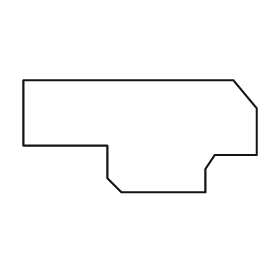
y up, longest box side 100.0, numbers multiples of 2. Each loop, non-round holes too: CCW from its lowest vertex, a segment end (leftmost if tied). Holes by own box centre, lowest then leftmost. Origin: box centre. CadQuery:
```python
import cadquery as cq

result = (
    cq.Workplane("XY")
    .moveTo(-8.0, -24.0)
    .lineTo(28.0, -24.0)
    .lineTo(28.0, -14.0)
    .lineTo(32.0, -8.0)
    .lineTo(50.0, -8.0)
    .lineTo(50.0, 12.0)
    .lineTo(40.0, 24.0)
    .lineTo(-50.0, 24.0)
    .lineTo(-50.0, -4.0)
    .lineTo(-14.0, -4.0)
    .lineTo(-14.0, -18.0)
    .close()
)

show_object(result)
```